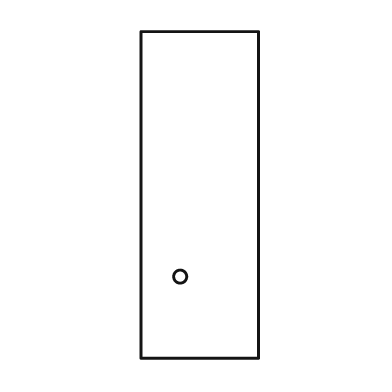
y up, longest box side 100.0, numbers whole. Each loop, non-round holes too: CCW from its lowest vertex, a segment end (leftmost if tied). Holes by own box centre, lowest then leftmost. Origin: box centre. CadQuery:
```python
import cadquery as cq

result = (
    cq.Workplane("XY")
    .moveTo(-18.0, -50.0)
    .lineTo(18.0, -50.0)
    .lineTo(18.0, 50.0)
    .lineTo(-18.0, 50.0)
    .close()
    .moveTo(-6.0, -25.0)
    .circle(2.0)
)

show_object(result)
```